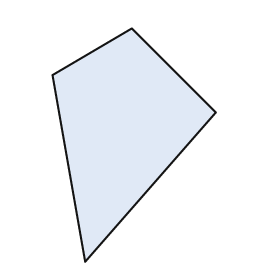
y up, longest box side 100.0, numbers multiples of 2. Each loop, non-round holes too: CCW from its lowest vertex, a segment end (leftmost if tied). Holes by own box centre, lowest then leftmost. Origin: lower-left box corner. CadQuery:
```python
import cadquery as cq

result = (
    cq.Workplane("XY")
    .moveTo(14.0, 0.0)
    .lineTo(70.0, 64.0)
    .lineTo(34.0, 100.0)
    .lineTo(0.0, 80.0)
    .close()
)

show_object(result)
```